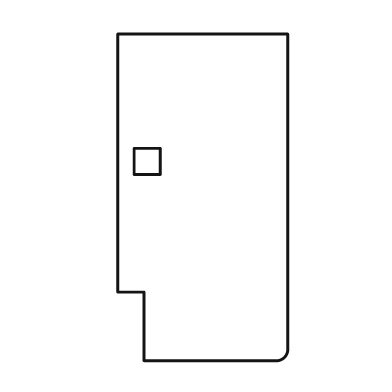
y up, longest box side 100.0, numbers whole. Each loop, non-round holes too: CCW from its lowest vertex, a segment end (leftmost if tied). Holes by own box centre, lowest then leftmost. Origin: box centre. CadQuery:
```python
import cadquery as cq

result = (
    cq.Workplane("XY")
    .moveTo(-18.0, -50.0)
    .lineTo(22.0, -50.0)
    .threePointArc((25.0, -49.0), (26.0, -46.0))
    .lineTo(26.0, 50.0)
    .lineTo(-26.0, 50.0)
    .lineTo(-26.0, -29.0)
    .lineTo(-18.0, -29.0)
    .close()
    .moveTo(-21.0, 7.0)
    .lineTo(-13.0, 7.0)
    .lineTo(-13.0, 15.0)
    .lineTo(-21.0, 15.0)
    .close()
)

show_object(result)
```